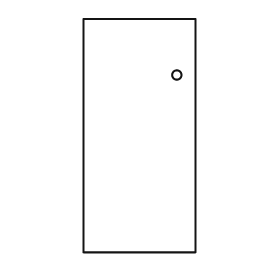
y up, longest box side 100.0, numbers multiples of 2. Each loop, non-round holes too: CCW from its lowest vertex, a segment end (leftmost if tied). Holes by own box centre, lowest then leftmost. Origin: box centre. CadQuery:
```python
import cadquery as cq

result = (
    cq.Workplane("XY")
    .moveTo(-24.0, -50.0)
    .lineTo(24.0, -50.0)
    .lineTo(24.0, 50.0)
    .lineTo(-24.0, 50.0)
    .close()
    .moveTo(16.0, 26.0)
    .circle(2.0)
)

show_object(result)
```